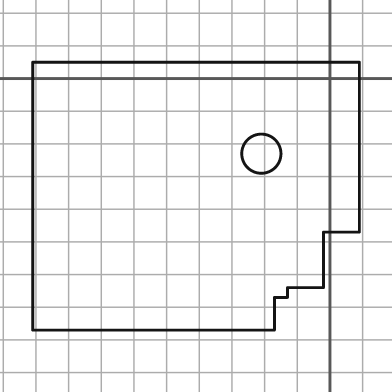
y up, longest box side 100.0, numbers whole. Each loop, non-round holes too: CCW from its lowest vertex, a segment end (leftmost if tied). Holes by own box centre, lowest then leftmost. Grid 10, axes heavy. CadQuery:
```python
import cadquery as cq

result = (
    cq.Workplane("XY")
    .moveTo(-91.0, -77.0)
    .lineTo(-17.0, -77.0)
    .lineTo(-17.0, -67.0)
    .lineTo(-13.0, -67.0)
    .lineTo(-13.0, -64.0)
    .lineTo(-2.0, -64.0)
    .lineTo(-2.0, -47.0)
    .lineTo(9.0, -47.0)
    .lineTo(9.0, 5.0)
    .lineTo(-91.0, 5.0)
    .close()
    .moveTo(-21.0, -23.0)
    .circle(6.0)
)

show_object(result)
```